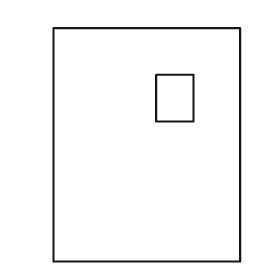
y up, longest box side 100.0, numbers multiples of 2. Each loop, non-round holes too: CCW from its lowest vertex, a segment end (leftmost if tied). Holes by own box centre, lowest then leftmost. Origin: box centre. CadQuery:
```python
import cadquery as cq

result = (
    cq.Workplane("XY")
    .moveTo(-40.0, -50.0)
    .lineTo(40.0, -50.0)
    .lineTo(40.0, 50.0)
    .lineTo(-40.0, 50.0)
    .close()
    .moveTo(4.0, 10.0)
    .lineTo(20.0, 10.0)
    .lineTo(20.0, 30.0)
    .lineTo(4.0, 30.0)
    .close()
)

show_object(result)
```